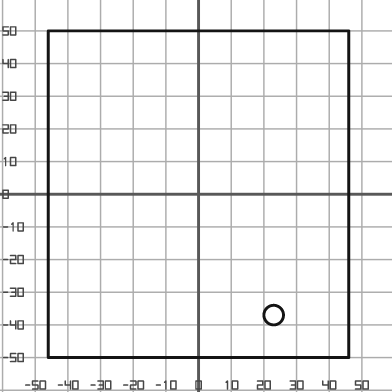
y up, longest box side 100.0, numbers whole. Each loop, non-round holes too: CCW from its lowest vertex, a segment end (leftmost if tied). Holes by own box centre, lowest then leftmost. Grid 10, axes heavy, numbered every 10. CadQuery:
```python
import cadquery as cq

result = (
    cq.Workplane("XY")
    .moveTo(-46.0, -50.0)
    .lineTo(46.0, -50.0)
    .lineTo(46.0, 50.0)
    .lineTo(-46.0, 50.0)
    .close()
    .moveTo(23.0, -37.0)
    .circle(3.0)
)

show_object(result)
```